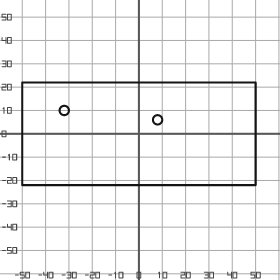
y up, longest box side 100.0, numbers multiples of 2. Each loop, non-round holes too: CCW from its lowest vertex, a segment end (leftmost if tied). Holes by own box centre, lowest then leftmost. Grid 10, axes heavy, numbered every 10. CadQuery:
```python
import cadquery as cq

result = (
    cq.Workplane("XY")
    .moveTo(-50.0, -22.0)
    .lineTo(50.0, -22.0)
    .lineTo(50.0, 22.0)
    .lineTo(-50.0, 22.0)
    .close()
    .moveTo(8.0, 6.0)
    .circle(2.0)
    .moveTo(-32.0, 10.0)
    .circle(2.0)
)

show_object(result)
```